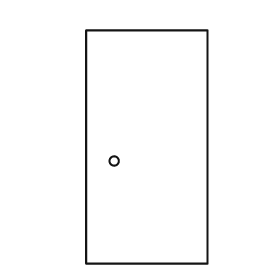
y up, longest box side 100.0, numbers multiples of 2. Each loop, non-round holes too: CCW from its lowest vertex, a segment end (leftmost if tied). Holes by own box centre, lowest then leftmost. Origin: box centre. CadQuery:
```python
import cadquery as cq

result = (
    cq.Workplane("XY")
    .moveTo(-26.0, -50.0)
    .lineTo(26.0, -50.0)
    .lineTo(26.0, 50.0)
    .lineTo(-26.0, 50.0)
    .close()
    .moveTo(-14.0, -6.0)
    .circle(2.0)
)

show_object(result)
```